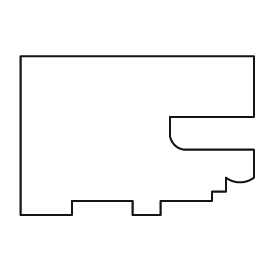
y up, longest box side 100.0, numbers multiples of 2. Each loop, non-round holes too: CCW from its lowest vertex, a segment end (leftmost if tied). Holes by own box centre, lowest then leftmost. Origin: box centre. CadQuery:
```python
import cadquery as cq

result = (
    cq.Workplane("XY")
    .moveTo(-50.0, -34.0)
    .lineTo(-28.0, -34.0)
    .lineTo(-28.0, -28.0)
    .lineTo(-2.0, -28.0)
    .lineTo(-2.0, -34.0)
    .lineTo(10.0, -34.0)
    .lineTo(10.0, -28.0)
    .lineTo(32.0, -28.0)
    .lineTo(32.0, -24.0)
    .lineTo(38.0, -24.0)
    .lineTo(38.0, -18.0)
    .threePointArc((44.0, -20.0), (50.0, -18.0))
    .lineTo(50.0, -6.0)
    .lineTo(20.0, -6.0)
    .threePointArc((16.0, -4.0), (14.0, 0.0))
    .lineTo(14.0, 8.0)
    .lineTo(50.0, 8.0)
    .lineTo(50.0, 34.0)
    .lineTo(-50.0, 34.0)
    .close()
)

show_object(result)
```